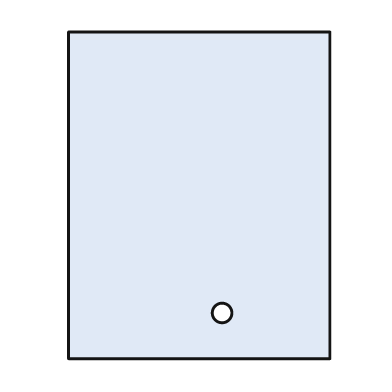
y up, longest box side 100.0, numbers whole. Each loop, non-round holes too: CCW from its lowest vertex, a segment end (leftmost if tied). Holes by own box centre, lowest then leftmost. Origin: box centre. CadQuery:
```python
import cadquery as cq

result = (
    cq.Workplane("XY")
    .moveTo(-40.0, -50.0)
    .lineTo(40.0, -50.0)
    .lineTo(40.0, 50.0)
    .lineTo(-40.0, 50.0)
    .close()
    .moveTo(7.0, -36.0)
    .circle(3.0)
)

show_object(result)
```